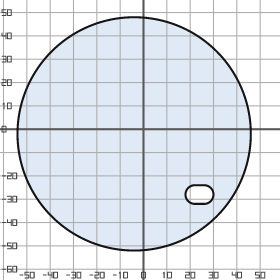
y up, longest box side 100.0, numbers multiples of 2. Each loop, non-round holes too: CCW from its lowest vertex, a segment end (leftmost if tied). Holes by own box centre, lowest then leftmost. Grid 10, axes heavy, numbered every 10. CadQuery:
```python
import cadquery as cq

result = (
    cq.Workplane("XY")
    .moveTo(-4.0, -2.0)
    .circle(50.0)
    .moveTo(22.0, -32.0)
    .lineTo(26.0, -32.0)
    .threePointArc((30.0, -28.0), (26.0, -24.0))
    .lineTo(22.0, -24.0)
    .threePointArc((18.0, -28.0), (22.0, -32.0))
    .close()
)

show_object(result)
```